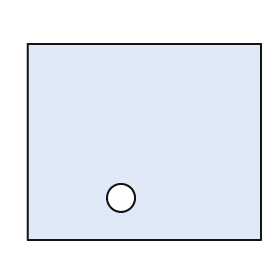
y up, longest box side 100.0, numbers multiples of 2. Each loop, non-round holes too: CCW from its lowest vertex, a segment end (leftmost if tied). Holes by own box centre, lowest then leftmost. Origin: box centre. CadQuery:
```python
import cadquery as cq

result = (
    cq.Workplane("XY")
    .moveTo(-50.0, -42.0)
    .lineTo(50.0, -42.0)
    .lineTo(50.0, 42.0)
    .lineTo(-50.0, 42.0)
    .close()
    .moveTo(-10.0, -24.0)
    .circle(6.0)
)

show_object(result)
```